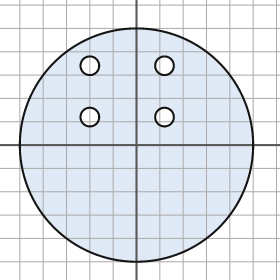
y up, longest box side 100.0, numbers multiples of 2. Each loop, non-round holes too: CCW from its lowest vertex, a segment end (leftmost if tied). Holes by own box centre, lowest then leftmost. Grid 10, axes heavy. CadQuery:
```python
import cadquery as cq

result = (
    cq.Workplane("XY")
    .moveTo(0.0, 0.0)
    .circle(50.0)
    .moveTo(-20.0, 12.0)
    .circle(4.0)
    .moveTo(12.0, 12.0)
    .circle(4.0)
    .moveTo(-20.0, 34.0)
    .circle(4.0)
    .moveTo(12.0, 34.0)
    .circle(4.0)
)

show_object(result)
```